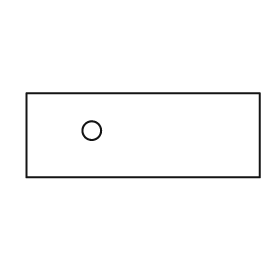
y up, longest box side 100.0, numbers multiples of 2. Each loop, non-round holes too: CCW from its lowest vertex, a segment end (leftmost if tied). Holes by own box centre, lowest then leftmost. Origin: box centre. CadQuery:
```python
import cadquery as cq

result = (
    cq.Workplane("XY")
    .moveTo(-50.0, -18.0)
    .lineTo(50.0, -18.0)
    .lineTo(50.0, 18.0)
    .lineTo(-50.0, 18.0)
    .close()
    .moveTo(-22.0, 2.0)
    .circle(4.0)
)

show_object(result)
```